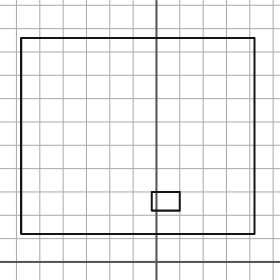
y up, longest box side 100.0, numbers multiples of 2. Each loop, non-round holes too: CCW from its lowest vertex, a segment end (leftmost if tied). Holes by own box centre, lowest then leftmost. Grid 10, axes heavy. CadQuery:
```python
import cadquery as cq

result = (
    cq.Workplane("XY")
    .moveTo(-58.0, 12.0)
    .lineTo(42.0, 12.0)
    .lineTo(42.0, 96.0)
    .lineTo(-58.0, 96.0)
    .close()
    .moveTo(-2.0, 22.0)
    .lineTo(10.0, 22.0)
    .lineTo(10.0, 30.0)
    .lineTo(-2.0, 30.0)
    .close()
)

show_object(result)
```